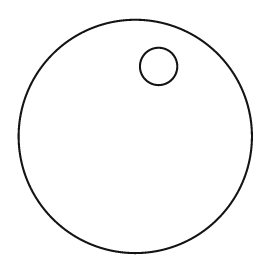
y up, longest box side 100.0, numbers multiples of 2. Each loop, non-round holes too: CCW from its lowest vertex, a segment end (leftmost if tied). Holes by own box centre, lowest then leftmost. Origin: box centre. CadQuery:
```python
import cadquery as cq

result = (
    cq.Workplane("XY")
    .moveTo(0.0, 0.0)
    .circle(50.0)
    .moveTo(10.0, 30.0)
    .circle(8.0)
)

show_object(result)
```